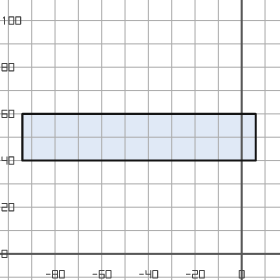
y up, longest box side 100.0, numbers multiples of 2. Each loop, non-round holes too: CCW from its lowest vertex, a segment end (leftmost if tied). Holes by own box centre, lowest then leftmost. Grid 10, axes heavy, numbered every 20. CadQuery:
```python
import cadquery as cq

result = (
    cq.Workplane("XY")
    .moveTo(-94.0, 40.0)
    .lineTo(6.0, 40.0)
    .lineTo(6.0, 60.0)
    .lineTo(-94.0, 60.0)
    .close()
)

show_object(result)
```